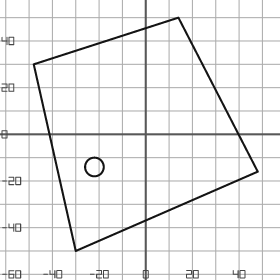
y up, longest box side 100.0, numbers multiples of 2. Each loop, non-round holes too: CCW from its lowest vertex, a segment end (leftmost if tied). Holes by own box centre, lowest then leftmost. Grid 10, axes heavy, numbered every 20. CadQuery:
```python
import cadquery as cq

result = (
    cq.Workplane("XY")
    .moveTo(-30.0, -50.0)
    .lineTo(48.0, -16.0)
    .lineTo(14.0, 50.0)
    .lineTo(-48.0, 30.0)
    .close()
    .moveTo(-22.0, -14.0)
    .circle(4.0)
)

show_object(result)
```